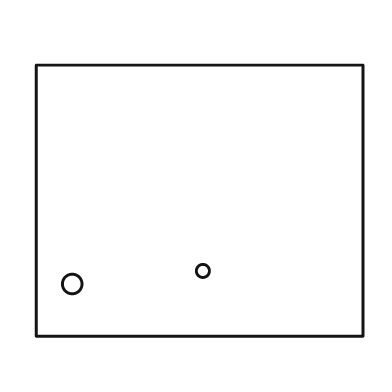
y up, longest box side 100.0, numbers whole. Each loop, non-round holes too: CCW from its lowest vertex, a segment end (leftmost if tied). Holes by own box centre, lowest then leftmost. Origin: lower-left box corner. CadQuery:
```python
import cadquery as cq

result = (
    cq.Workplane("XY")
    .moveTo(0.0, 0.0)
    .lineTo(100.0, 0.0)
    .lineTo(100.0, 83.0)
    .lineTo(0.0, 83.0)
    .close()
    .moveTo(11.0, 16.0)
    .circle(3.0)
    .moveTo(51.0, 20.0)
    .circle(2.0)
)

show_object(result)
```